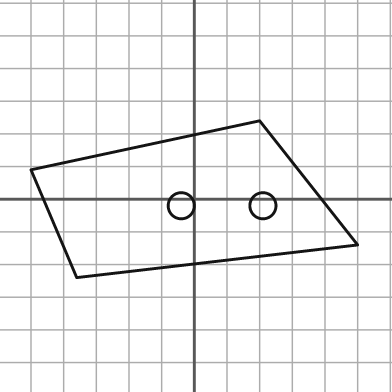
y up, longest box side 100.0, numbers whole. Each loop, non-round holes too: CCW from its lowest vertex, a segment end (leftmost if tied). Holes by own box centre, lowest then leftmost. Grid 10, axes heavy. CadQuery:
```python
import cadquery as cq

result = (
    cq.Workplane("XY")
    .moveTo(-36.0, -24.0)
    .lineTo(50.0, -14.0)
    .lineTo(20.0, 24.0)
    .lineTo(-50.0, 9.0)
    .close()
    .moveTo(-4.0, -2.0)
    .circle(4.0)
    .moveTo(21.0, -2.0)
    .circle(4.0)
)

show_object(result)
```